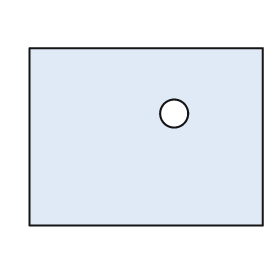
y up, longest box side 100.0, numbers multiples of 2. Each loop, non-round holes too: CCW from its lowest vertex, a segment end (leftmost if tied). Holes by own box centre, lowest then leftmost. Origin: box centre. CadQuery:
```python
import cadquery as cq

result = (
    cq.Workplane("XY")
    .moveTo(-50.0, -38.0)
    .lineTo(50.0, -38.0)
    .lineTo(50.0, 38.0)
    .lineTo(-50.0, 38.0)
    .close()
    .moveTo(12.0, 10.0)
    .circle(6.0)
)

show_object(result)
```